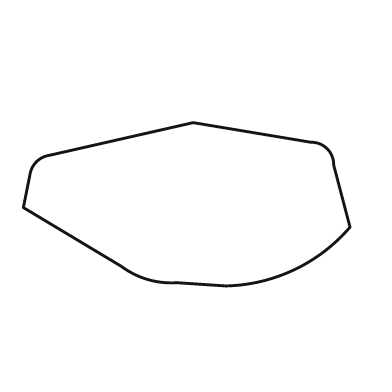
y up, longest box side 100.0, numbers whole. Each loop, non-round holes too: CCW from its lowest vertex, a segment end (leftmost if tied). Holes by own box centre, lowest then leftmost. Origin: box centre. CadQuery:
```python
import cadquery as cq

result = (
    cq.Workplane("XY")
    .moveTo(12.0, -25.0)
    .threePointArc((33.0, -20.0), (50.0, -7.0))
    .lineTo(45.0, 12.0)
    .threePointArc((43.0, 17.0), (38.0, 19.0))
    .lineTo(2.0, 25.0)
    .lineTo(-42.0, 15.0)
    .threePointArc((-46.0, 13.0), (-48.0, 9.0))
    .lineTo(-50.0, -1.0)
    .lineTo(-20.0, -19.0)
    .threePointArc((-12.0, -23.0), (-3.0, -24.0))
    .close()
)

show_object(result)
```